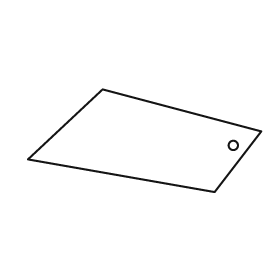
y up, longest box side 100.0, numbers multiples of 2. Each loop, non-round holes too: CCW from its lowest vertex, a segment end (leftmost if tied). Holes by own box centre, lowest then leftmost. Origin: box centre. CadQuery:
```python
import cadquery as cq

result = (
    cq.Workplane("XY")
    .moveTo(30.0, -22.0)
    .lineTo(50.0, 4.0)
    .lineTo(-18.0, 22.0)
    .lineTo(-50.0, -8.0)
    .close()
    .moveTo(38.0, -2.0)
    .circle(2.0)
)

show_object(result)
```